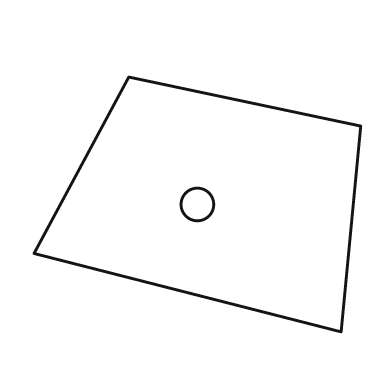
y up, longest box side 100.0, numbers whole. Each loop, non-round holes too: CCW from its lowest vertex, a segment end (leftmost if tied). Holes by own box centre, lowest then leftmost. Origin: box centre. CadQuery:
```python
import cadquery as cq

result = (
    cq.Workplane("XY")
    .moveTo(44.0, -39.0)
    .lineTo(50.0, 24.0)
    .lineTo(-21.0, 39.0)
    .lineTo(-50.0, -15.0)
    .close()
    .moveTo(0.0, 0.0)
    .circle(5.0)
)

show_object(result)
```